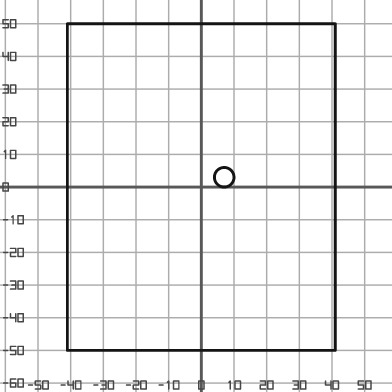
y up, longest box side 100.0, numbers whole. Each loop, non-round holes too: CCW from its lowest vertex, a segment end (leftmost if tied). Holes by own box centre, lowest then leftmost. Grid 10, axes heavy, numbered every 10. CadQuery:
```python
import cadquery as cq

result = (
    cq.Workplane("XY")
    .moveTo(-41.0, -50.0)
    .lineTo(41.0, -50.0)
    .lineTo(41.0, 50.0)
    .lineTo(-41.0, 50.0)
    .close()
    .moveTo(7.0, 3.0)
    .circle(3.0)
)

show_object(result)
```